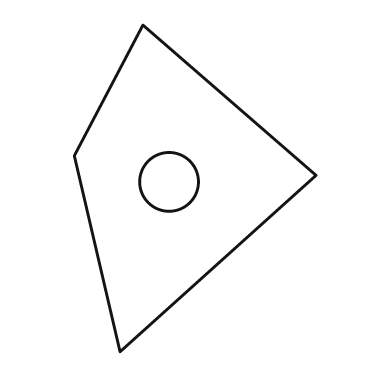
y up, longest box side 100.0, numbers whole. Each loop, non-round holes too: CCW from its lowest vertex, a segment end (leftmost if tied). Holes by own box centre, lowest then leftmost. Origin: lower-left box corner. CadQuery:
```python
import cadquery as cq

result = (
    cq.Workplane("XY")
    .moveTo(14.0, 0.0)
    .lineTo(74.0, 54.0)
    .lineTo(21.0, 100.0)
    .lineTo(0.0, 60.0)
    .close()
    .moveTo(29.0, 52.0)
    .circle(9.0)
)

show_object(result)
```